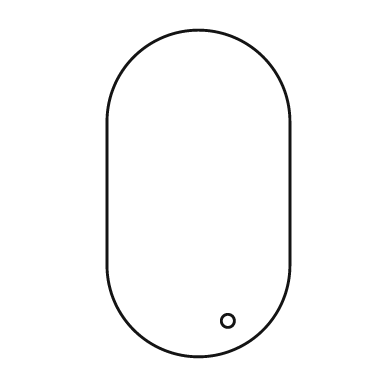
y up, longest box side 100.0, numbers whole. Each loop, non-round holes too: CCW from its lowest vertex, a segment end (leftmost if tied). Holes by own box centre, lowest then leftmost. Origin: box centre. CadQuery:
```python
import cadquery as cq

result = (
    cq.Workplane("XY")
    .moveTo(-28.0, -22.0)
    .threePointArc((0.0, -50.0), (28.0, -22.0))
    .lineTo(28.0, 22.0)
    .threePointArc((0.0, 50.0), (-28.0, 22.0))
    .close()
    .moveTo(9.0, -39.0)
    .circle(2.0)
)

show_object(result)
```